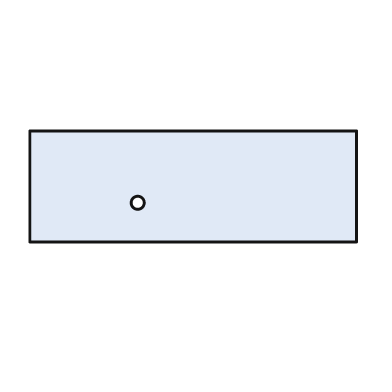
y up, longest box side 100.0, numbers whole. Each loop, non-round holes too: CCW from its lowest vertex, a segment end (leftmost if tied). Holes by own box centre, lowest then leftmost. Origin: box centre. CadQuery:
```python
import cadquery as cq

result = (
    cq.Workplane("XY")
    .moveTo(-50.0, -17.0)
    .lineTo(50.0, -17.0)
    .lineTo(50.0, 17.0)
    .lineTo(-50.0, 17.0)
    .close()
    .moveTo(-17.0, -5.0)
    .circle(2.0)
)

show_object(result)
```